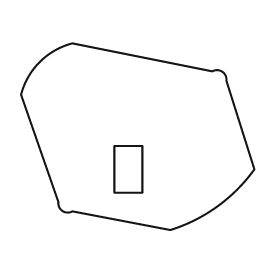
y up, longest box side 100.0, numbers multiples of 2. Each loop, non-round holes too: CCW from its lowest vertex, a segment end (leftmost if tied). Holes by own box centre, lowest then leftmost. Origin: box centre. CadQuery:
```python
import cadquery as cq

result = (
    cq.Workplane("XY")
    .moveTo(14.0, -40.0)
    .threePointArc((34.0, -30.0), (50.0, -14.0))
    .lineTo(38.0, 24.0)
    .threePointArc((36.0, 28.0), (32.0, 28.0))
    .lineTo(-28.0, 40.0)
    .threePointArc((-42.0, 32.0), (-50.0, 18.0))
    .lineTo(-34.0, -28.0)
    .threePointArc((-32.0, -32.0), (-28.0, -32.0))
    .close()
    .moveTo(-10.0, -24.0)
    .lineTo(2.0, -24.0)
    .lineTo(2.0, -4.0)
    .lineTo(-10.0, -4.0)
    .close()
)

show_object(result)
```